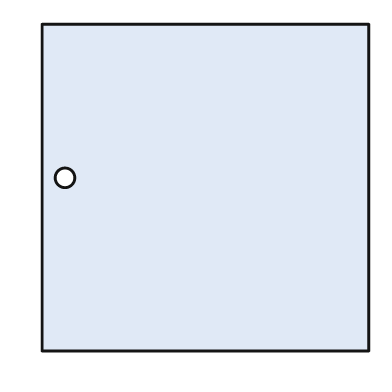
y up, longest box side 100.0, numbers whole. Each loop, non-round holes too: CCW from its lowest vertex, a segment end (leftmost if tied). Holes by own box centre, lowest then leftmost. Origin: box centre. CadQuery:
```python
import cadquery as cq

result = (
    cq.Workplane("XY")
    .moveTo(-50.0, -50.0)
    .lineTo(50.0, -50.0)
    .lineTo(50.0, 50.0)
    .lineTo(-50.0, 50.0)
    .close()
    .moveTo(-43.0, 3.0)
    .circle(3.0)
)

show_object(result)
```